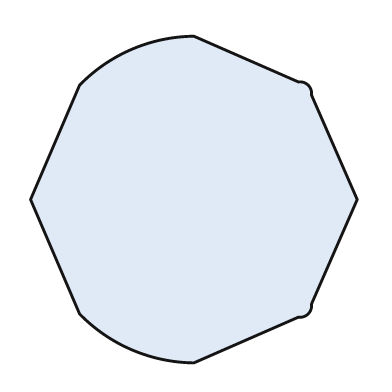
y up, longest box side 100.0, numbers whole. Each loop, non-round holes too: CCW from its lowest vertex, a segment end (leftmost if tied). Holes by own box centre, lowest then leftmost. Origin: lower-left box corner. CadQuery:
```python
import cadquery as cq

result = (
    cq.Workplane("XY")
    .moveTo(50.0, 0.0)
    .lineTo(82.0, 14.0)
    .threePointArc((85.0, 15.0), (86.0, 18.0))
    .lineTo(100.0, 50.0)
    .lineTo(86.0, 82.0)
    .threePointArc((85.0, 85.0), (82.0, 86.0))
    .lineTo(50.0, 100.0)
    .threePointArc((31.0, 96.0), (15.0, 85.0))
    .lineTo(0.0, 50.0)
    .lineTo(15.0, 15.0)
    .threePointArc((31.0, 4.0), (50.0, 0.0))
    .close()
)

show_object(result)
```